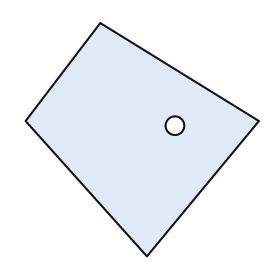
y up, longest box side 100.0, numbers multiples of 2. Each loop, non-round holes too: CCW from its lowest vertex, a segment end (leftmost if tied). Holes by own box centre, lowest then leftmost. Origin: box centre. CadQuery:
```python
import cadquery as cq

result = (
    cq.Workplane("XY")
    .moveTo(2.0, -50.0)
    .lineTo(50.0, 8.0)
    .lineTo(-18.0, 50.0)
    .lineTo(-50.0, 8.0)
    .close()
    .moveTo(14.0, 6.0)
    .circle(4.0)
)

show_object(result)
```